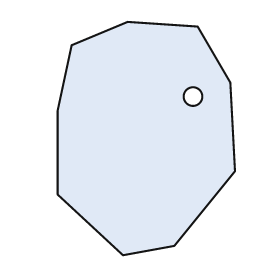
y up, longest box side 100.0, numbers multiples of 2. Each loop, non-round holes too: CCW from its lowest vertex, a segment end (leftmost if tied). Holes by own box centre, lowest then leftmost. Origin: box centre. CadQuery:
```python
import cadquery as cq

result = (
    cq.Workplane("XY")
    .moveTo(-10.0, -50.0)
    .lineTo(12.0, -46.0)
    .lineTo(38.0, -14.0)
    .lineTo(36.0, 24.0)
    .lineTo(22.0, 48.0)
    .lineTo(-8.0, 50.0)
    .lineTo(-32.0, 40.0)
    .lineTo(-38.0, 12.0)
    .lineTo(-38.0, -24.0)
    .close()
    .moveTo(20.0, 18.0)
    .circle(4.0)
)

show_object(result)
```